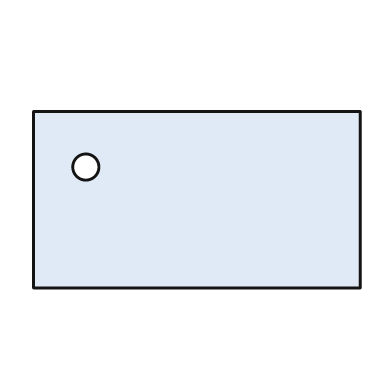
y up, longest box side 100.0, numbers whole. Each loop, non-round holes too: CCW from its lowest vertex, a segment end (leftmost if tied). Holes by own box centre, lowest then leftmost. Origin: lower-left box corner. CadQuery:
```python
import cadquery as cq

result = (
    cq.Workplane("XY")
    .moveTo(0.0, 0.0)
    .lineTo(100.0, 0.0)
    .lineTo(100.0, 54.0)
    .lineTo(0.0, 54.0)
    .close()
    .moveTo(16.0, 37.0)
    .circle(4.0)
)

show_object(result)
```